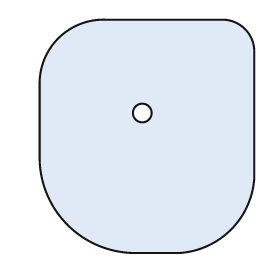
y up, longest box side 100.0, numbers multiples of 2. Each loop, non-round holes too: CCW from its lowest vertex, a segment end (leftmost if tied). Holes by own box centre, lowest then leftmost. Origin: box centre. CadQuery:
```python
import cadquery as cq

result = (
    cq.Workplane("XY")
    .moveTo(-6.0, -50.0)
    .lineTo(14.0, -50.0)
    .threePointArc((36.0, -40.0), (46.0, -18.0))
    .lineTo(46.0, 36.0)
    .threePointArc((42.0, 46.0), (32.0, 50.0))
    .lineTo(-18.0, 50.0)
    .threePointArc((-38.0, 42.0), (-46.0, 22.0))
    .lineTo(-46.0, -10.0)
    .threePointArc((-34.0, -38.0), (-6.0, -50.0))
    .close()
    .moveTo(-2.0, 10.0)
    .circle(4.0)
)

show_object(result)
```